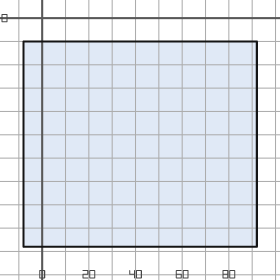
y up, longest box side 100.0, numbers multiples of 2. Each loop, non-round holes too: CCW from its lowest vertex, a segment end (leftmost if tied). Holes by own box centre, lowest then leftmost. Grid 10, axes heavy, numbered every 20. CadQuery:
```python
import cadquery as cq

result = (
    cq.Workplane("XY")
    .moveTo(-8.0, -98.0)
    .lineTo(92.0, -98.0)
    .lineTo(92.0, -10.0)
    .lineTo(-8.0, -10.0)
    .close()
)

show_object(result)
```